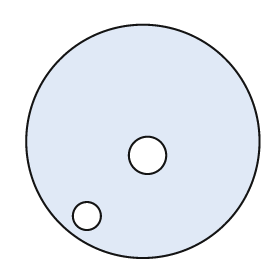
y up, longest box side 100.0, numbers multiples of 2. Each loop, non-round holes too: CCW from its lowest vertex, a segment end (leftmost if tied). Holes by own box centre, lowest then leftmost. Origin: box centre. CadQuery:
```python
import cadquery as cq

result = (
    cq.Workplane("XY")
    .moveTo(0.0, 0.0)
    .circle(50.0)
    .moveTo(-24.0, -32.0)
    .circle(6.0)
    .moveTo(2.0, -6.0)
    .circle(8.0)
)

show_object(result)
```